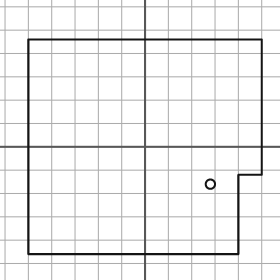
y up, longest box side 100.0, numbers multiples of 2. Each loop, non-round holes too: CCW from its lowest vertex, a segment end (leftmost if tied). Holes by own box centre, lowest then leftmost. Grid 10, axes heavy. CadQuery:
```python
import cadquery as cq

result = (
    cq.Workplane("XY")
    .moveTo(-50.0, -46.0)
    .lineTo(40.0, -46.0)
    .lineTo(40.0, -12.0)
    .lineTo(50.0, -12.0)
    .lineTo(50.0, 46.0)
    .lineTo(-50.0, 46.0)
    .close()
    .moveTo(28.0, -16.0)
    .circle(2.0)
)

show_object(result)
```